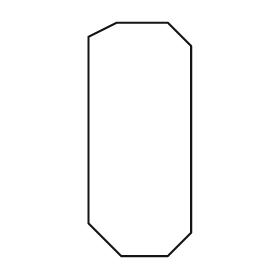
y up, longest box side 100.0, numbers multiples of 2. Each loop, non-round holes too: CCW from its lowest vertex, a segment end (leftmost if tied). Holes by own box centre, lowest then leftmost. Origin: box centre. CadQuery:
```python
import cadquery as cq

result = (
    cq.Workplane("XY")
    .moveTo(-8.0, -50.0)
    .lineTo(12.0, -50.0)
    .lineTo(22.0, -40.0)
    .lineTo(22.0, 40.0)
    .lineTo(12.0, 50.0)
    .lineTo(-10.0, 50.0)
    .lineTo(-22.0, 44.0)
    .lineTo(-22.0, -36.0)
    .close()
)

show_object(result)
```